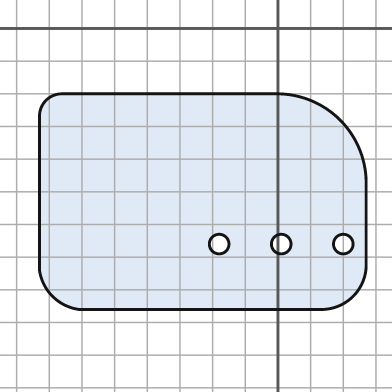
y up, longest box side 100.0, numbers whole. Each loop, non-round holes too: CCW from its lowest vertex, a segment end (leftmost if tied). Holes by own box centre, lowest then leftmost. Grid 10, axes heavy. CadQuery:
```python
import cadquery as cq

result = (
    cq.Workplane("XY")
    .moveTo(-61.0, -86.0)
    .lineTo(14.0, -86.0)
    .threePointArc((23.0, -82.0), (27.0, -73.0))
    .lineTo(27.0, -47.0)
    .threePointArc((19.0, -28.0), (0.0, -20.0))
    .lineTo(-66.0, -20.0)
    .threePointArc((-71.0, -22.0), (-73.0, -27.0))
    .lineTo(-73.0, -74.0)
    .threePointArc((-69.0, -82.0), (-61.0, -86.0))
    .close()
    .moveTo(-18.0, -66.0)
    .circle(3.0)
    .moveTo(1.0, -66.0)
    .circle(3.0)
    .moveTo(20.0, -66.0)
    .circle(3.0)
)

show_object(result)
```